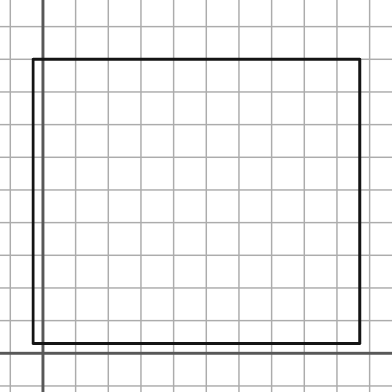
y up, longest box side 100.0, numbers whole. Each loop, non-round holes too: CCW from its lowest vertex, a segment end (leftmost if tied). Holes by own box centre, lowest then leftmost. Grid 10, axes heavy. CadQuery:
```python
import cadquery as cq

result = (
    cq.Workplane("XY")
    .moveTo(-3.0, 3.0)
    .lineTo(97.0, 3.0)
    .lineTo(97.0, 90.0)
    .lineTo(-3.0, 90.0)
    .close()
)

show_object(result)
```